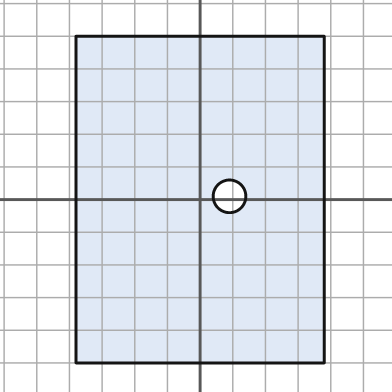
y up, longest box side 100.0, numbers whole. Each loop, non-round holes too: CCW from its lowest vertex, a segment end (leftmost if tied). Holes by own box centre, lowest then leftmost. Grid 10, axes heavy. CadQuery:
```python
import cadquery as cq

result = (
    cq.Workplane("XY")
    .moveTo(-38.0, -50.0)
    .lineTo(38.0, -50.0)
    .lineTo(38.0, 50.0)
    .lineTo(-38.0, 50.0)
    .close()
    .moveTo(9.0, 1.0)
    .circle(5.0)
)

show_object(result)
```